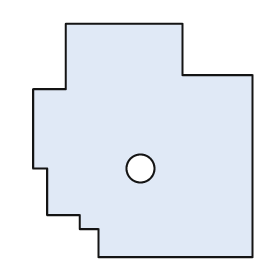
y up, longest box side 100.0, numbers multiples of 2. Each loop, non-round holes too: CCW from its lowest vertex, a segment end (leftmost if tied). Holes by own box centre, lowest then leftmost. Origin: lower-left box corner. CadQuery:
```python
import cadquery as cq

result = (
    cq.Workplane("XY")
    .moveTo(28.0, 0.0)
    .lineTo(94.0, 0.0)
    .lineTo(94.0, 78.0)
    .lineTo(64.0, 78.0)
    .lineTo(64.0, 100.0)
    .lineTo(14.0, 100.0)
    .lineTo(14.0, 72.0)
    .lineTo(0.0, 72.0)
    .lineTo(0.0, 38.0)
    .lineTo(6.0, 38.0)
    .lineTo(6.0, 18.0)
    .lineTo(20.0, 18.0)
    .lineTo(20.0, 12.0)
    .lineTo(28.0, 12.0)
    .close()
    .moveTo(46.0, 38.0)
    .circle(6.0)
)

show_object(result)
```